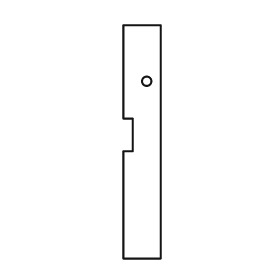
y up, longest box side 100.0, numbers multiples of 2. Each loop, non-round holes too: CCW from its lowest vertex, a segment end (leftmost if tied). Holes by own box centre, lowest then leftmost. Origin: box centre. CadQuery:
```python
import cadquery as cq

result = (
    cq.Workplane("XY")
    .moveTo(-8.0, -50.0)
    .lineTo(8.0, -50.0)
    .lineTo(8.0, 50.0)
    .lineTo(-8.0, 50.0)
    .lineTo(-8.0, 10.0)
    .lineTo(-4.0, 10.0)
    .lineTo(-4.0, -4.0)
    .lineTo(-8.0, -4.0)
    .close()
    .moveTo(2.0, 26.0)
    .circle(2.0)
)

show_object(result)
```